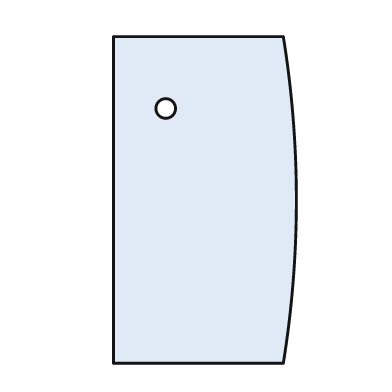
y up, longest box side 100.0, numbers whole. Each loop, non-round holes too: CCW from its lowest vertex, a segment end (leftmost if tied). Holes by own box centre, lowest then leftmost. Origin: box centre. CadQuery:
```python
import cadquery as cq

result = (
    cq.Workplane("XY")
    .moveTo(-28.0, -50.0)
    .lineTo(24.0, -50.0)
    .threePointArc((28.0, 0.0), (24.0, 50.0))
    .lineTo(-28.0, 50.0)
    .close()
    .moveTo(-12.0, 28.0)
    .circle(3.0)
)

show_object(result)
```